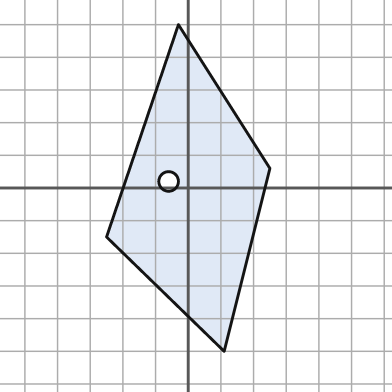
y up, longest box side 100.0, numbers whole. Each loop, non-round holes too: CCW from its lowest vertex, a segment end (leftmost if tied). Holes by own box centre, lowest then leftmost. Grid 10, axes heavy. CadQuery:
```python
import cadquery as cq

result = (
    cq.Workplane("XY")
    .moveTo(11.0, -50.0)
    .lineTo(25.0, 6.0)
    .lineTo(-3.0, 50.0)
    .lineTo(-25.0, -15.0)
    .close()
    .moveTo(-6.0, 2.0)
    .circle(3.0)
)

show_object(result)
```